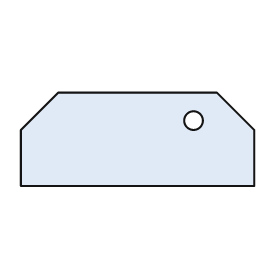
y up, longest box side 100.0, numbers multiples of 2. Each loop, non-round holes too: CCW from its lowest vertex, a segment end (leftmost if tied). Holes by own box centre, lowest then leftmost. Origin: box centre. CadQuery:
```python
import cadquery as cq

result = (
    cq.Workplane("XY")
    .moveTo(-50.0, -20.0)
    .lineTo(50.0, -20.0)
    .lineTo(50.0, 4.0)
    .lineTo(34.0, 20.0)
    .lineTo(-34.0, 20.0)
    .lineTo(-50.0, 4.0)
    .close()
    .moveTo(24.0, 8.0)
    .circle(4.0)
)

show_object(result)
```